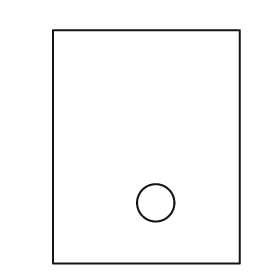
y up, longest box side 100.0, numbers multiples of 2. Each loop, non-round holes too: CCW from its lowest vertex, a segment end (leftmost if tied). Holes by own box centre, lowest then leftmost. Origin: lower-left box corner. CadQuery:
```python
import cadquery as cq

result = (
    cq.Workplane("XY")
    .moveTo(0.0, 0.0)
    .lineTo(80.0, 0.0)
    .lineTo(80.0, 100.0)
    .lineTo(0.0, 100.0)
    .close()
    .moveTo(44.0, 26.0)
    .circle(8.0)
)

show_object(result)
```